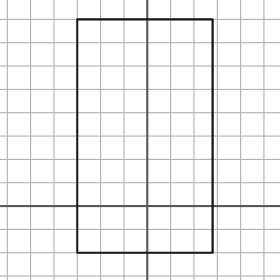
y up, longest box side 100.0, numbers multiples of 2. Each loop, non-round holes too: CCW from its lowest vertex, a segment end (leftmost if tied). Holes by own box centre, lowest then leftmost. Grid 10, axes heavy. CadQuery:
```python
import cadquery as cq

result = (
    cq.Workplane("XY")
    .moveTo(-30.0, -20.0)
    .lineTo(28.0, -20.0)
    .lineTo(28.0, 80.0)
    .lineTo(-30.0, 80.0)
    .close()
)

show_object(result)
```